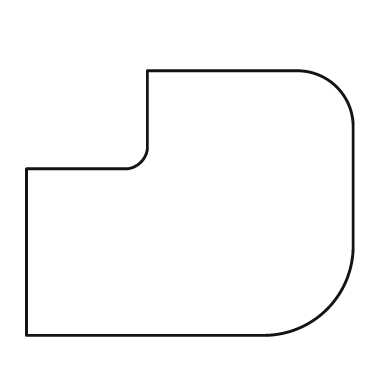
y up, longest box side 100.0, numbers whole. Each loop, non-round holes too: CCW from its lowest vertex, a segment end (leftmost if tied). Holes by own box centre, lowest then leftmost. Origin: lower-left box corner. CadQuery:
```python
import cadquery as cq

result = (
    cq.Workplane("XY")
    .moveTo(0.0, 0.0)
    .lineTo(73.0, 0.0)
    .threePointArc((92.0, 8.0), (100.0, 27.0))
    .lineTo(100.0, 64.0)
    .threePointArc((95.0, 76.0), (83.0, 81.0))
    .lineTo(37.0, 81.0)
    .lineTo(37.0, 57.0)
    .threePointArc((35.0, 53.0), (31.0, 51.0))
    .lineTo(0.0, 51.0)
    .close()
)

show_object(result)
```